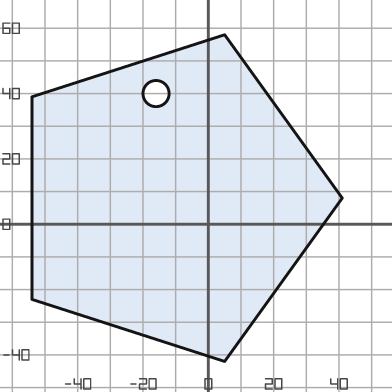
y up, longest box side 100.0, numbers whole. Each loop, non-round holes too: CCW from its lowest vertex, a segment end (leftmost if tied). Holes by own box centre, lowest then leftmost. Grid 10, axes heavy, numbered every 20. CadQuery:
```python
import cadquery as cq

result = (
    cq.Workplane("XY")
    .moveTo(5.0, -42.0)
    .lineTo(41.0, 8.0)
    .lineTo(5.0, 58.0)
    .lineTo(-54.0, 39.0)
    .lineTo(-54.0, -23.0)
    .close()
    .moveTo(-16.0, 40.0)
    .circle(4.0)
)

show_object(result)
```